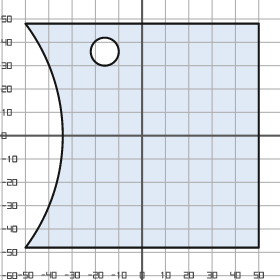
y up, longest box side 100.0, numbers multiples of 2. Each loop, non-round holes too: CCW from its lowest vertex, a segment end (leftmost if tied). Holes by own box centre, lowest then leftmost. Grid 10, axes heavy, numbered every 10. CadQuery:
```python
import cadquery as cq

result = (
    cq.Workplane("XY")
    .moveTo(-50.0, -48.0)
    .lineTo(50.0, -48.0)
    .lineTo(50.0, 48.0)
    .lineTo(-50.0, 48.0)
    .threePointArc((-34.0, 0.0), (-50.0, -48.0))
    .close()
    .moveTo(-16.0, 36.0)
    .circle(6.0)
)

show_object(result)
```